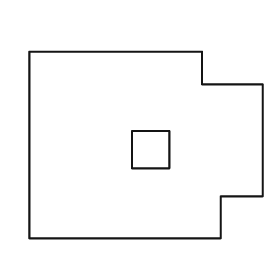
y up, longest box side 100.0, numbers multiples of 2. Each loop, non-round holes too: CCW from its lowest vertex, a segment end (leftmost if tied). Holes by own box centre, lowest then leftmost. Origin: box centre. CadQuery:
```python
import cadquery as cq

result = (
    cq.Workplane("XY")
    .moveTo(-50.0, -40.0)
    .lineTo(32.0, -40.0)
    .lineTo(32.0, -22.0)
    .lineTo(50.0, -22.0)
    .lineTo(50.0, 26.0)
    .lineTo(24.0, 26.0)
    .lineTo(24.0, 40.0)
    .lineTo(-50.0, 40.0)
    .close()
    .moveTo(-6.0, -10.0)
    .lineTo(10.0, -10.0)
    .lineTo(10.0, 6.0)
    .lineTo(-6.0, 6.0)
    .close()
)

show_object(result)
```